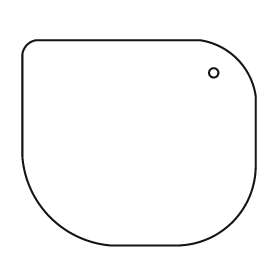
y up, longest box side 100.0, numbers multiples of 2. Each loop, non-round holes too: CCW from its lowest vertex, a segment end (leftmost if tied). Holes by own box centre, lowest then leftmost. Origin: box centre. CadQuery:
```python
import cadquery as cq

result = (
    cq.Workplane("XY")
    .moveTo(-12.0, -44.0)
    .lineTo(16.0, -44.0)
    .threePointArc((40.0, -34.0), (50.0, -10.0))
    .lineTo(50.0, 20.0)
    .threePointArc((42.0, 36.0), (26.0, 44.0))
    .lineTo(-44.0, 44.0)
    .threePointArc((-48.0, 42.0), (-50.0, 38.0))
    .lineTo(-50.0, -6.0)
    .threePointArc((-38.0, -32.0), (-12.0, -44.0))
    .close()
    .moveTo(32.0, 30.0)
    .circle(2.0)
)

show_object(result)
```